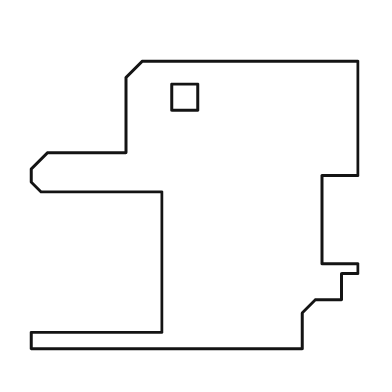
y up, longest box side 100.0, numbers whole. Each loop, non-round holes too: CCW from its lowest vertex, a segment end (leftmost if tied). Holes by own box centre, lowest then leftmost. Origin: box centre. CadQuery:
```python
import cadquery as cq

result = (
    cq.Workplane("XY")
    .moveTo(-50.0, -44.0)
    .lineTo(33.0, -44.0)
    .lineTo(33.0, -33.0)
    .lineTo(37.0, -29.0)
    .lineTo(45.0, -29.0)
    .lineTo(45.0, -21.0)
    .lineTo(50.0, -21.0)
    .lineTo(50.0, -18.0)
    .lineTo(39.0, -18.0)
    .lineTo(39.0, 9.0)
    .lineTo(50.0, 9.0)
    .lineTo(50.0, 44.0)
    .lineTo(-16.0, 44.0)
    .lineTo(-21.0, 39.0)
    .lineTo(-21.0, 16.0)
    .lineTo(-45.0, 16.0)
    .lineTo(-50.0, 11.0)
    .lineTo(-50.0, 7.0)
    .lineTo(-47.0, 4.0)
    .lineTo(-10.0, 4.0)
    .lineTo(-10.0, -39.0)
    .lineTo(-50.0, -39.0)
    .close()
    .moveTo(-7.0, 29.0)
    .lineTo(1.0, 29.0)
    .lineTo(1.0, 37.0)
    .lineTo(-7.0, 37.0)
    .close()
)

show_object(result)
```